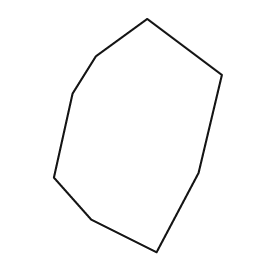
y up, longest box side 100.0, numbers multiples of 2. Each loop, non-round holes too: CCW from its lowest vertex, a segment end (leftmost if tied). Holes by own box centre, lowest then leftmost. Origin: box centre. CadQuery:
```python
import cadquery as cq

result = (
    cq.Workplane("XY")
    .moveTo(8.0, -50.0)
    .lineTo(26.0, -16.0)
    .lineTo(36.0, 26.0)
    .lineTo(4.0, 50.0)
    .lineTo(-18.0, 34.0)
    .lineTo(-28.0, 18.0)
    .lineTo(-36.0, -18.0)
    .lineTo(-20.0, -36.0)
    .close()
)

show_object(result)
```